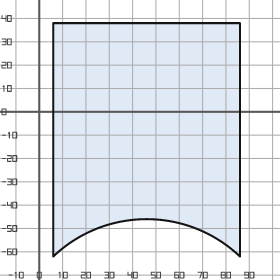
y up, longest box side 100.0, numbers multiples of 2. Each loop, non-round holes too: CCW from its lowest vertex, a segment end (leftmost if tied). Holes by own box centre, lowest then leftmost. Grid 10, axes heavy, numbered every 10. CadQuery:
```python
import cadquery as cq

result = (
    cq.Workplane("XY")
    .moveTo(6.0, -62.0)
    .threePointArc((46.0, -46.0), (86.0, -62.0))
    .lineTo(86.0, 38.0)
    .lineTo(6.0, 38.0)
    .close()
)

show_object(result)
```